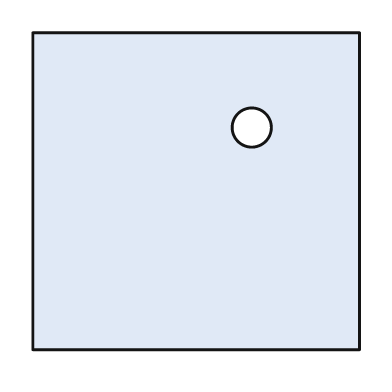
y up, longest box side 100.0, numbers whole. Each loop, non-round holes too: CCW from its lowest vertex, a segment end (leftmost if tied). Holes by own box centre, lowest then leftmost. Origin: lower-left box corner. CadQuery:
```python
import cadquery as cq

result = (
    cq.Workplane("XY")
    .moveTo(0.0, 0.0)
    .lineTo(100.0, 0.0)
    .lineTo(100.0, 97.0)
    .lineTo(0.0, 97.0)
    .close()
    .moveTo(67.0, 68.0)
    .circle(6.0)
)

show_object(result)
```